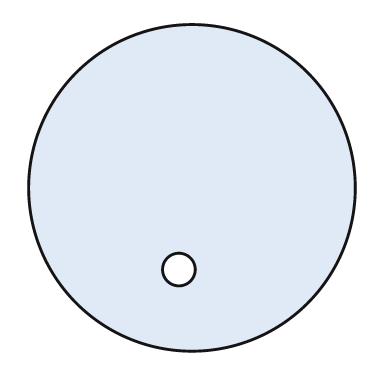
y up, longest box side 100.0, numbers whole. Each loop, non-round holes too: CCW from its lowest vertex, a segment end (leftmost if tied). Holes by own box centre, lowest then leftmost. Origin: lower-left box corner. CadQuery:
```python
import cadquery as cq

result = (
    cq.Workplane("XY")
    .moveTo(50.0, 50.0)
    .circle(50.0)
    .moveTo(46.0, 25.0)
    .circle(5.0)
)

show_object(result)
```